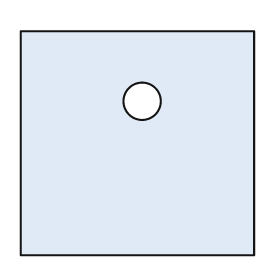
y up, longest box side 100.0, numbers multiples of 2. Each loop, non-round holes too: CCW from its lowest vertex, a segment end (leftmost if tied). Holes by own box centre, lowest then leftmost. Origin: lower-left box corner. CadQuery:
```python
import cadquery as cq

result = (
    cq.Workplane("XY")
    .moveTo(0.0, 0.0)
    .lineTo(100.0, 0.0)
    .lineTo(100.0, 96.0)
    .lineTo(0.0, 96.0)
    .close()
    .moveTo(52.0, 66.0)
    .circle(8.0)
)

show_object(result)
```